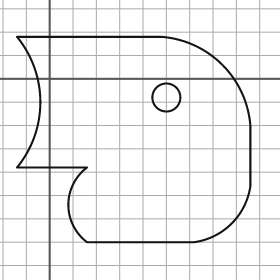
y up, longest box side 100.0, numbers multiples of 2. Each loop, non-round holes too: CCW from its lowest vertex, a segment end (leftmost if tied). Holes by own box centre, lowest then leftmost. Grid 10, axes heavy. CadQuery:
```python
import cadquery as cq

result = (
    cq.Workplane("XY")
    .moveTo(16.0, -70.0)
    .lineTo(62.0, -70.0)
    .threePointArc((78.0, -62.0), (86.0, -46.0))
    .lineTo(86.0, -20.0)
    .threePointArc((74.0, 6.0), (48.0, 18.0))
    .lineTo(-14.0, 18.0)
    .threePointArc((-4.0, -10.0), (-14.0, -38.0))
    .lineTo(16.0, -38.0)
    .threePointArc((8.0, -54.0), (16.0, -70.0))
    .close()
    .moveTo(50.0, -8.0)
    .circle(6.0)
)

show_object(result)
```